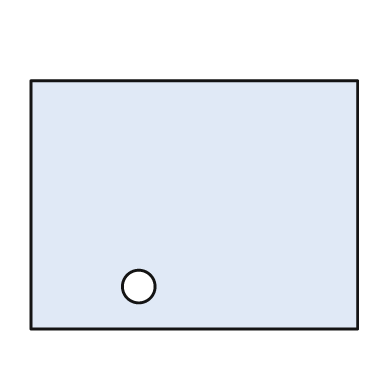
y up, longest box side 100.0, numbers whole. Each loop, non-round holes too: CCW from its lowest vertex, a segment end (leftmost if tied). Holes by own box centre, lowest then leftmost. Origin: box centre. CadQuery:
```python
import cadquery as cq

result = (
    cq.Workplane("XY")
    .moveTo(-50.0, -38.0)
    .lineTo(50.0, -38.0)
    .lineTo(50.0, 38.0)
    .lineTo(-50.0, 38.0)
    .close()
    .moveTo(-17.0, -25.0)
    .circle(5.0)
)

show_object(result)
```